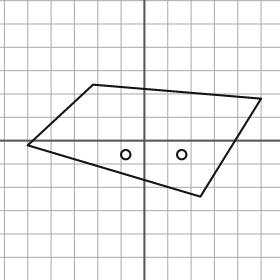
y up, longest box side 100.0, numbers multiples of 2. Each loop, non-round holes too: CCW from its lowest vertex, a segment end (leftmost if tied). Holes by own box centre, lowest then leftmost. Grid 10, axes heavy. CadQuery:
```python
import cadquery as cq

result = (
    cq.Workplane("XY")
    .moveTo(24.0, -24.0)
    .lineTo(50.0, 18.0)
    .lineTo(-22.0, 24.0)
    .lineTo(-50.0, -2.0)
    .close()
    .moveTo(-8.0, -6.0)
    .circle(2.0)
    .moveTo(16.0, -6.0)
    .circle(2.0)
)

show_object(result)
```